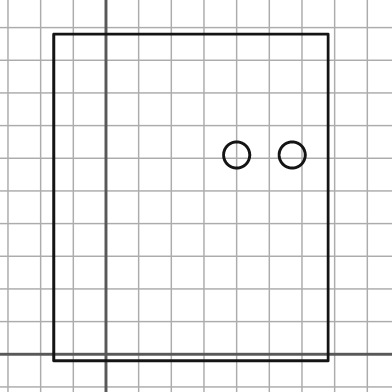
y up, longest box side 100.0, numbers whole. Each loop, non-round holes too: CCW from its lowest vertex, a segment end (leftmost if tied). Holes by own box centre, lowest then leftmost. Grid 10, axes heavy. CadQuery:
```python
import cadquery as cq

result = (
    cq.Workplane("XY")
    .moveTo(-16.0, -2.0)
    .lineTo(68.0, -2.0)
    .lineTo(68.0, 98.0)
    .lineTo(-16.0, 98.0)
    .close()
    .moveTo(40.0, 61.0)
    .circle(4.0)
    .moveTo(57.0, 61.0)
    .circle(4.0)
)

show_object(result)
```